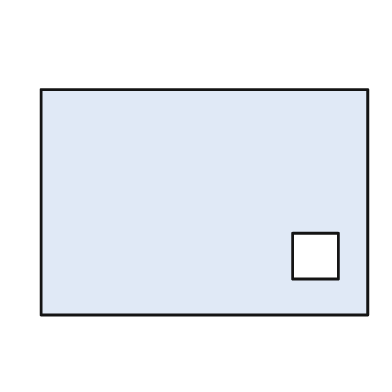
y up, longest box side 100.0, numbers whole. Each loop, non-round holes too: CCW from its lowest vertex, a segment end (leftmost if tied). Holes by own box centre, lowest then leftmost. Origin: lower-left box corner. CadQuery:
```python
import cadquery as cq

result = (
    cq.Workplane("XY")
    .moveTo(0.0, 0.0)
    .lineTo(100.0, 0.0)
    .lineTo(100.0, 69.0)
    .lineTo(0.0, 69.0)
    .close()
    .moveTo(77.0, 11.0)
    .lineTo(91.0, 11.0)
    .lineTo(91.0, 25.0)
    .lineTo(77.0, 25.0)
    .close()
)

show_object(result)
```